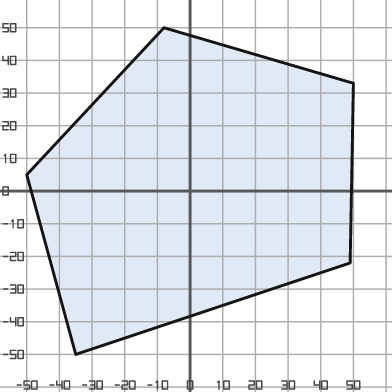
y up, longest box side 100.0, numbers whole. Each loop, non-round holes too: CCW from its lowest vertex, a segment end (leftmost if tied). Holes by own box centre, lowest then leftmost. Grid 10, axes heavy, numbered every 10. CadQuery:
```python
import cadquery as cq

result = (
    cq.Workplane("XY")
    .moveTo(-35.0, -50.0)
    .lineTo(49.0, -22.0)
    .lineTo(50.0, 33.0)
    .lineTo(-8.0, 50.0)
    .lineTo(-50.0, 5.0)
    .close()
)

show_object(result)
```